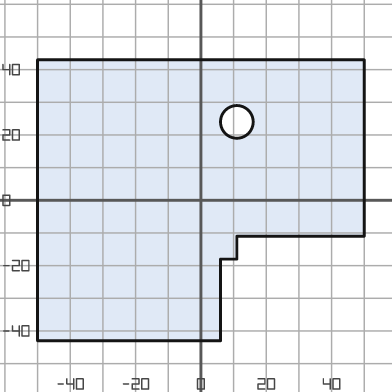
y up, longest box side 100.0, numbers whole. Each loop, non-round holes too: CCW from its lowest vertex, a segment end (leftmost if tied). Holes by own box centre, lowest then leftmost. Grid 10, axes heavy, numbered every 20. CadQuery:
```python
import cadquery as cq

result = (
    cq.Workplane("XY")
    .moveTo(-50.0, -43.0)
    .lineTo(6.0, -43.0)
    .lineTo(6.0, -18.0)
    .lineTo(11.0, -18.0)
    .lineTo(11.0, -11.0)
    .lineTo(50.0, -11.0)
    .lineTo(50.0, 43.0)
    .lineTo(-50.0, 43.0)
    .close()
    .moveTo(11.0, 24.0)
    .circle(5.0)
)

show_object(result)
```